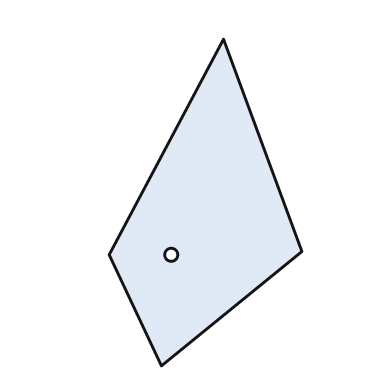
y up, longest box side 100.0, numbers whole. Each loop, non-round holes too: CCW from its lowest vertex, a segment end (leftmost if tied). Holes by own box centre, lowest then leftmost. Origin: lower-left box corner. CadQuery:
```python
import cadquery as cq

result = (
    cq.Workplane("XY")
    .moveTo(16.0, 0.0)
    .lineTo(59.0, 35.0)
    .lineTo(35.0, 100.0)
    .lineTo(0.0, 34.0)
    .close()
    .moveTo(19.0, 34.0)
    .circle(2.0)
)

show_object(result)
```